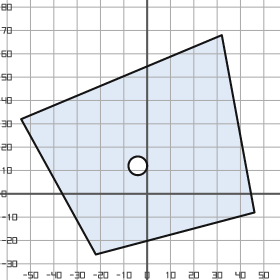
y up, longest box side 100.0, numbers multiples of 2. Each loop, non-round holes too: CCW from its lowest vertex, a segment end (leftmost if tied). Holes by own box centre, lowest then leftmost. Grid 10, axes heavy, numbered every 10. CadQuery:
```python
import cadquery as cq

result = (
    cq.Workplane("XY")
    .moveTo(-22.0, -26.0)
    .lineTo(46.0, -8.0)
    .lineTo(32.0, 68.0)
    .lineTo(-54.0, 32.0)
    .close()
    .moveTo(-4.0, 12.0)
    .circle(4.0)
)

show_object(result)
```